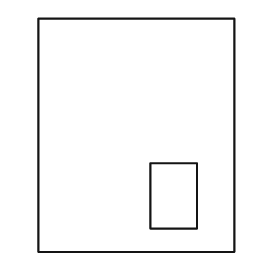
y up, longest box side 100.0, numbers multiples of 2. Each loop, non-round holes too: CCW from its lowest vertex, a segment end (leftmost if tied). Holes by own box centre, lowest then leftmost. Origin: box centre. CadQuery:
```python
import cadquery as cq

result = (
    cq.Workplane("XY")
    .moveTo(-42.0, -50.0)
    .lineTo(42.0, -50.0)
    .lineTo(42.0, 50.0)
    .lineTo(-42.0, 50.0)
    .close()
    .moveTo(6.0, -40.0)
    .lineTo(26.0, -40.0)
    .lineTo(26.0, -12.0)
    .lineTo(6.0, -12.0)
    .close()
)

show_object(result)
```